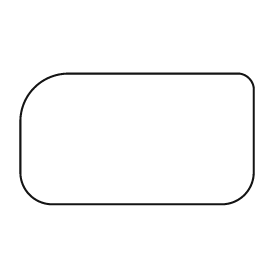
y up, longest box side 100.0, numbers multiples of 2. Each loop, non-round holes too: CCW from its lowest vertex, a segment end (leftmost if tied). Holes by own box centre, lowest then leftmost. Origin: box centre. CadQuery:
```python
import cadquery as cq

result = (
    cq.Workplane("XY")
    .moveTo(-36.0, -28.0)
    .lineTo(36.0, -28.0)
    .threePointArc((46.0, -24.0), (50.0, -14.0))
    .lineTo(50.0, 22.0)
    .threePointArc((48.0, 26.0), (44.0, 28.0))
    .lineTo(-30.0, 28.0)
    .threePointArc((-44.0, 22.0), (-50.0, 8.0))
    .lineTo(-50.0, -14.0)
    .threePointArc((-46.0, -24.0), (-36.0, -28.0))
    .close()
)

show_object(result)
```